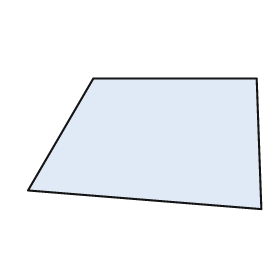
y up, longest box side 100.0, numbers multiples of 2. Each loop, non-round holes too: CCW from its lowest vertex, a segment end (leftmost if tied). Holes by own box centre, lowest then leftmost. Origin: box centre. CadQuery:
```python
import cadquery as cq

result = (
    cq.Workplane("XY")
    .moveTo(50.0, -28.0)
    .lineTo(48.0, 28.0)
    .lineTo(-22.0, 28.0)
    .lineTo(-50.0, -20.0)
    .close()
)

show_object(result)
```